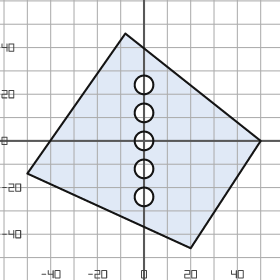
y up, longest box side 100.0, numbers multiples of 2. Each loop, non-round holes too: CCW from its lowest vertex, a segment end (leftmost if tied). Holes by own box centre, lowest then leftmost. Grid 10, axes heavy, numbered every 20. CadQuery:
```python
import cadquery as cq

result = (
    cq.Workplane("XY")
    .moveTo(20.0, -46.0)
    .lineTo(50.0, 0.0)
    .lineTo(-8.0, 46.0)
    .lineTo(-50.0, -14.0)
    .close()
    .moveTo(0.0, -24.0)
    .circle(4.0)
    .moveTo(0.0, -12.0)
    .circle(4.0)
    .moveTo(0.0, 0.0)
    .circle(4.0)
    .moveTo(0.0, 12.0)
    .circle(4.0)
    .moveTo(0.0, 24.0)
    .circle(4.0)
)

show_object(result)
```